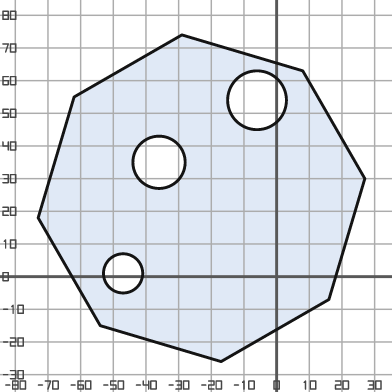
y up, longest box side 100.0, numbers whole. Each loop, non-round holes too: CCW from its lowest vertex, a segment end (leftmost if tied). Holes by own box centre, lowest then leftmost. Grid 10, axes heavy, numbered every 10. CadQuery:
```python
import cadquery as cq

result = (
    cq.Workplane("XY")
    .moveTo(-17.0, -26.0)
    .lineTo(16.0, -7.0)
    .lineTo(27.0, 30.0)
    .lineTo(8.0, 63.0)
    .lineTo(-29.0, 74.0)
    .lineTo(-62.0, 55.0)
    .lineTo(-73.0, 18.0)
    .lineTo(-54.0, -15.0)
    .close()
    .moveTo(-47.0, 1.0)
    .circle(6.0)
    .moveTo(-36.0, 35.0)
    .circle(8.0)
    .moveTo(-6.0, 54.0)
    .circle(9.0)
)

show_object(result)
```